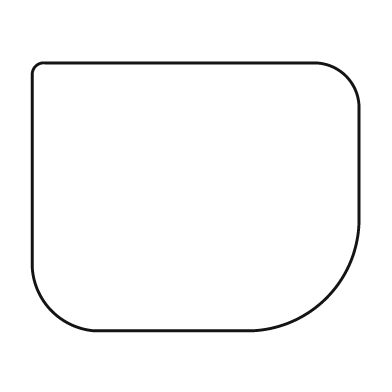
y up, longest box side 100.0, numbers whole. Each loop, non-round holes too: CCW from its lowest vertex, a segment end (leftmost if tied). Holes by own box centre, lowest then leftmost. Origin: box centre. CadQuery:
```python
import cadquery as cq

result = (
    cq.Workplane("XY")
    .moveTo(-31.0, -41.0)
    .lineTo(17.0, -41.0)
    .threePointArc((40.0, -31.0), (50.0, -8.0))
    .lineTo(50.0, 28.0)
    .threePointArc((46.0, 37.0), (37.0, 41.0))
    .lineTo(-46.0, 41.0)
    .threePointArc((-49.0, 40.0), (-50.0, 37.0))
    .lineTo(-50.0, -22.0)
    .threePointArc((-44.0, -35.0), (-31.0, -41.0))
    .close()
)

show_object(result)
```